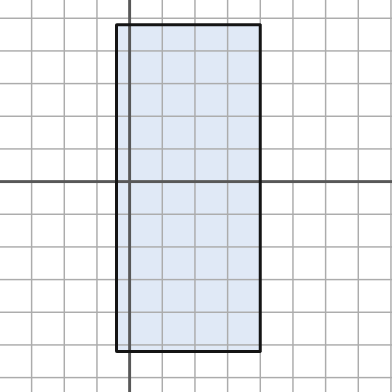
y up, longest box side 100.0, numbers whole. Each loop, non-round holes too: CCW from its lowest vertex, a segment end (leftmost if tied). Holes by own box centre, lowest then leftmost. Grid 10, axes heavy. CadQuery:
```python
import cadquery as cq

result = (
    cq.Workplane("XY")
    .moveTo(-4.0, -52.0)
    .lineTo(40.0, -52.0)
    .lineTo(40.0, 48.0)
    .lineTo(-4.0, 48.0)
    .close()
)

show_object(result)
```